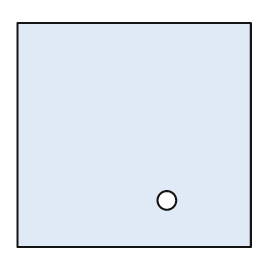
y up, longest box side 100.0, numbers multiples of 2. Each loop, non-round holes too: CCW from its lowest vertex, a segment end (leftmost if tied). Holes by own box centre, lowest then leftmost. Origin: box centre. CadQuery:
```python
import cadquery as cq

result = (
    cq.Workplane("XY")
    .moveTo(-50.0, -48.0)
    .lineTo(50.0, -48.0)
    .lineTo(50.0, 48.0)
    .lineTo(-50.0, 48.0)
    .close()
    .moveTo(14.0, -28.0)
    .circle(4.0)
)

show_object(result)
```